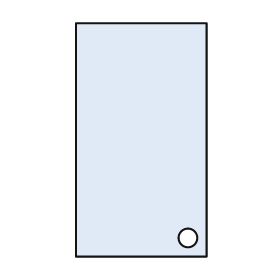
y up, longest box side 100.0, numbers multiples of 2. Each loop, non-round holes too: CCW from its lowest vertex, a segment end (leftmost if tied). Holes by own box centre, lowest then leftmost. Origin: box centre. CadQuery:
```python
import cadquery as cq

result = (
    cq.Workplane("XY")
    .moveTo(-28.0, -50.0)
    .lineTo(28.0, -50.0)
    .lineTo(28.0, 50.0)
    .lineTo(-28.0, 50.0)
    .close()
    .moveTo(20.0, -42.0)
    .circle(4.0)
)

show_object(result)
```